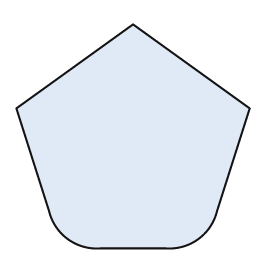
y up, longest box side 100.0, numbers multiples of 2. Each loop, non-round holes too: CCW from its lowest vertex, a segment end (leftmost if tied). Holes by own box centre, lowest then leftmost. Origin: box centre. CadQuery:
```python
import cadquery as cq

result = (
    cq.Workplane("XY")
    .moveTo(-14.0, -48.0)
    .lineTo(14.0, -48.0)
    .threePointArc((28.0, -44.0), (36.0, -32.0))
    .lineTo(50.0, 12.0)
    .lineTo(0.0, 48.0)
    .lineTo(-50.0, 12.0)
    .lineTo(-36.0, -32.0)
    .threePointArc((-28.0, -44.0), (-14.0, -48.0))
    .close()
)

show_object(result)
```